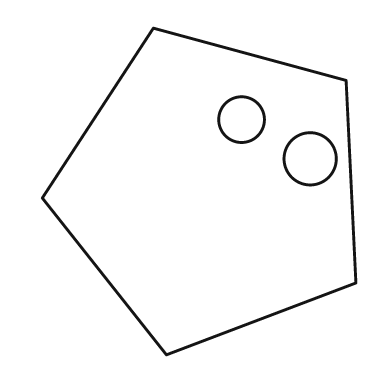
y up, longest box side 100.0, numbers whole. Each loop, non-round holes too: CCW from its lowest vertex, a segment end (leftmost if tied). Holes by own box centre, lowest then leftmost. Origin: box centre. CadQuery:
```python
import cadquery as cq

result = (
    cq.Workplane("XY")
    .moveTo(-10.0, -50.0)
    .lineTo(48.0, -28.0)
    .lineTo(45.0, 34.0)
    .lineTo(-14.0, 50.0)
    .lineTo(-48.0, -2.0)
    .close()
    .moveTo(34.0, 10.0)
    .circle(8.0)
    .moveTo(13.0, 22.0)
    .circle(7.0)
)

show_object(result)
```